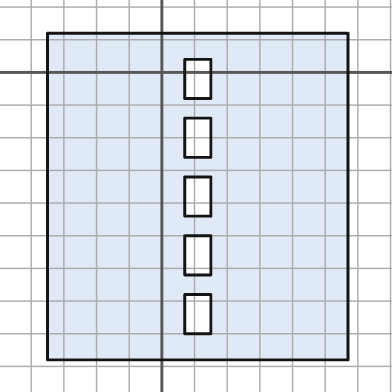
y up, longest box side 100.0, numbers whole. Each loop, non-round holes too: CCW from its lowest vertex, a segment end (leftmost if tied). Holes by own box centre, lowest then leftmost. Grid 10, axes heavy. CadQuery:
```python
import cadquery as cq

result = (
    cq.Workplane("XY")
    .moveTo(-35.0, -88.0)
    .lineTo(57.0, -88.0)
    .lineTo(57.0, 12.0)
    .lineTo(-35.0, 12.0)
    .close()
    .moveTo(7.0, -80.0)
    .lineTo(15.0, -80.0)
    .lineTo(15.0, -68.0)
    .lineTo(7.0, -68.0)
    .close()
    .moveTo(7.0, -62.0)
    .lineTo(15.0, -62.0)
    .lineTo(15.0, -50.0)
    .lineTo(7.0, -50.0)
    .close()
    .moveTo(7.0, -44.0)
    .lineTo(15.0, -44.0)
    .lineTo(15.0, -32.0)
    .lineTo(7.0, -32.0)
    .close()
    .moveTo(7.0, -26.0)
    .lineTo(15.0, -26.0)
    .lineTo(15.0, -14.0)
    .lineTo(7.0, -14.0)
    .close()
    .moveTo(7.0, -8.0)
    .lineTo(15.0, -8.0)
    .lineTo(15.0, 4.0)
    .lineTo(7.0, 4.0)
    .close()
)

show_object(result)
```